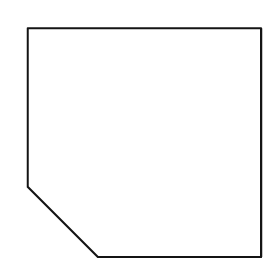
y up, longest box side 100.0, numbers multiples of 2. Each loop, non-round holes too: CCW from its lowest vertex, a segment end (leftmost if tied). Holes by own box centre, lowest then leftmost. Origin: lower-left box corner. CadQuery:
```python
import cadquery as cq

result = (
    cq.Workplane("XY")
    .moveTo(30.0, 0.0)
    .lineTo(100.0, 0.0)
    .lineTo(100.0, 98.0)
    .lineTo(0.0, 98.0)
    .lineTo(0.0, 30.0)
    .close()
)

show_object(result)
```